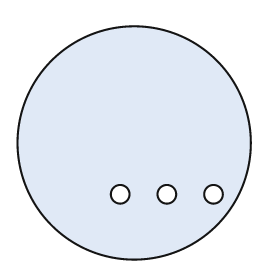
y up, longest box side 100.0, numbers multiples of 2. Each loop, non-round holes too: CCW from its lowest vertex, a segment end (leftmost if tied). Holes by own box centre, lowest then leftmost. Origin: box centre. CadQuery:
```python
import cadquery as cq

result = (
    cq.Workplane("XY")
    .moveTo(0.0, 0.0)
    .circle(50.0)
    .moveTo(-6.0, -22.0)
    .circle(4.0)
    .moveTo(14.0, -22.0)
    .circle(4.0)
    .moveTo(34.0, -22.0)
    .circle(4.0)
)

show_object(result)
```